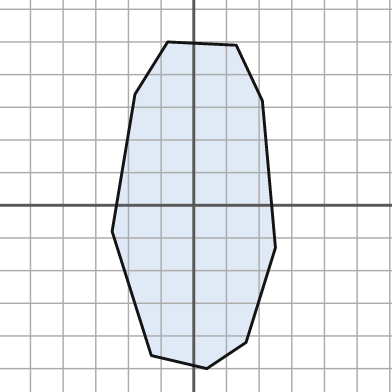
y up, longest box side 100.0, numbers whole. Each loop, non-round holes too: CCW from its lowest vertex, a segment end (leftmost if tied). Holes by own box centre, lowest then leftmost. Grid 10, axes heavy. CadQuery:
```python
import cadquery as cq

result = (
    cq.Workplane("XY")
    .moveTo(4.0, -50.0)
    .lineTo(16.0, -42.0)
    .lineTo(25.0, -13.0)
    .lineTo(21.0, 32.0)
    .lineTo(13.0, 49.0)
    .lineTo(-8.0, 50.0)
    .lineTo(-18.0, 34.0)
    .lineTo(-25.0, -8.0)
    .lineTo(-13.0, -46.0)
    .close()
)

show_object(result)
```